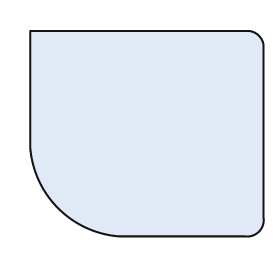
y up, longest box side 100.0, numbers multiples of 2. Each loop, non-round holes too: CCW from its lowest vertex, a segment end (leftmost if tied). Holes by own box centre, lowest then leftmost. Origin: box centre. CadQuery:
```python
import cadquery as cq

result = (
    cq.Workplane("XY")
    .moveTo(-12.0, -44.0)
    .lineTo(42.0, -44.0)
    .threePointArc((48.0, -42.0), (50.0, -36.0))
    .lineTo(50.0, 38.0)
    .threePointArc((48.0, 42.0), (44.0, 44.0))
    .lineTo(-50.0, 44.0)
    .lineTo(-50.0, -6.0)
    .threePointArc((-38.0, -32.0), (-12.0, -44.0))
    .close()
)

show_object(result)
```